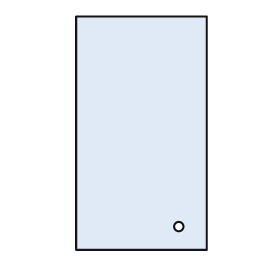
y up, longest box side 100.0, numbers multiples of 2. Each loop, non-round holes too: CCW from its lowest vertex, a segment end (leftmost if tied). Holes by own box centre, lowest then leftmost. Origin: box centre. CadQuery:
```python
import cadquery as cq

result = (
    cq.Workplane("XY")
    .moveTo(-28.0, -50.0)
    .lineTo(28.0, -50.0)
    .lineTo(28.0, 50.0)
    .lineTo(-28.0, 50.0)
    .close()
    .moveTo(16.0, -40.0)
    .circle(2.0)
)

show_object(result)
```